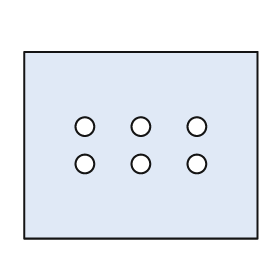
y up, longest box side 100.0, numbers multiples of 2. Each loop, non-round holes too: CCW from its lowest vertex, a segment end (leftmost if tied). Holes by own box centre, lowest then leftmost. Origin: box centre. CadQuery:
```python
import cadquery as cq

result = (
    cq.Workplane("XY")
    .moveTo(-50.0, -40.0)
    .lineTo(50.0, -40.0)
    .lineTo(50.0, 40.0)
    .lineTo(-50.0, 40.0)
    .close()
    .moveTo(-24.0, -8.0)
    .circle(4.0)
    .moveTo(0.0, -8.0)
    .circle(4.0)
    .moveTo(24.0, -8.0)
    .circle(4.0)
    .moveTo(-24.0, 8.0)
    .circle(4.0)
    .moveTo(0.0, 8.0)
    .circle(4.0)
    .moveTo(24.0, 8.0)
    .circle(4.0)
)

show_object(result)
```